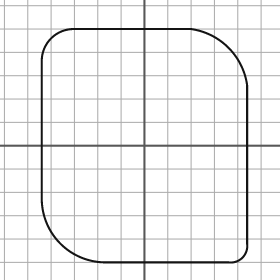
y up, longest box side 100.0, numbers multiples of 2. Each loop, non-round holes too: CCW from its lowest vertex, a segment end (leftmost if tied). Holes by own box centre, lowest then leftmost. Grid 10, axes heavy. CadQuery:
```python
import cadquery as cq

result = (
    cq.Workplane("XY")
    .moveTo(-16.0, -50.0)
    .lineTo(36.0, -50.0)
    .threePointArc((42.0, -48.0), (44.0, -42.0))
    .lineTo(44.0, 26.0)
    .threePointArc((36.0, 42.0), (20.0, 50.0))
    .lineTo(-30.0, 50.0)
    .threePointArc((-40.0, 46.0), (-44.0, 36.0))
    .lineTo(-44.0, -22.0)
    .threePointArc((-36.0, -42.0), (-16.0, -50.0))
    .close()
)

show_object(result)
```